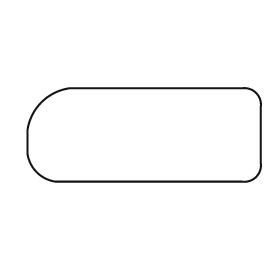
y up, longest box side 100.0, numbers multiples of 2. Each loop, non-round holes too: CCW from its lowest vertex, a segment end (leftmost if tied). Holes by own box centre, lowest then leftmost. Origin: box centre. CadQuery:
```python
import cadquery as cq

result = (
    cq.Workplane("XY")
    .moveTo(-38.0, -20.0)
    .lineTo(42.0, -20.0)
    .threePointArc((48.0, -18.0), (50.0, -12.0))
    .lineTo(50.0, 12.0)
    .threePointArc((48.0, 18.0), (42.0, 20.0))
    .lineTo(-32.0, 20.0)
    .threePointArc((-44.0, 14.0), (-50.0, 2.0))
    .lineTo(-50.0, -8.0)
    .threePointArc((-46.0, -16.0), (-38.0, -20.0))
    .close()
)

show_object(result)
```